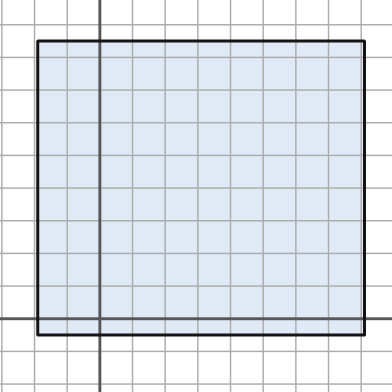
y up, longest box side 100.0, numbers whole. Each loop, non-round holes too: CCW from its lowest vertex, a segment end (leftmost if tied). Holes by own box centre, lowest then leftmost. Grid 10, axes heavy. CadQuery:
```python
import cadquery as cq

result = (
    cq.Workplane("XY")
    .moveTo(-19.0, -5.0)
    .lineTo(81.0, -5.0)
    .lineTo(81.0, 85.0)
    .lineTo(-19.0, 85.0)
    .close()
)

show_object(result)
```